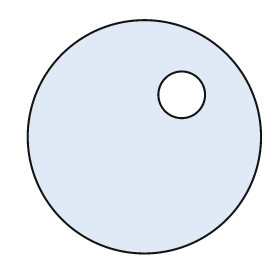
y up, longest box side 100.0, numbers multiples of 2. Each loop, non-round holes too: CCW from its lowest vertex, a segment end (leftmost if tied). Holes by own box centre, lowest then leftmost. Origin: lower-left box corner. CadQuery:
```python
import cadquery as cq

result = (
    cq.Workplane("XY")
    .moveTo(50.0, 50.0)
    .circle(50.0)
    .moveTo(66.0, 68.0)
    .circle(10.0)
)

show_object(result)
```